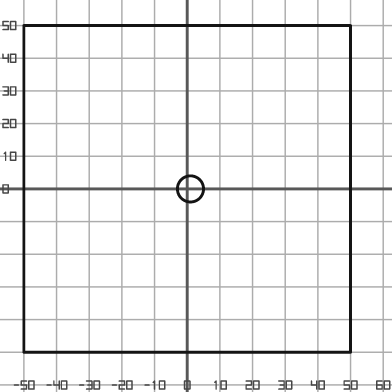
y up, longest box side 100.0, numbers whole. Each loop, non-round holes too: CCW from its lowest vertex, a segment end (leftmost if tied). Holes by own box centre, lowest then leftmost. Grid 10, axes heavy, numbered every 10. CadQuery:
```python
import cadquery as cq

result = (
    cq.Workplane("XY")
    .moveTo(-50.0, -50.0)
    .lineTo(50.0, -50.0)
    .lineTo(50.0, 50.0)
    .lineTo(-50.0, 50.0)
    .close()
    .moveTo(1.0, 0.0)
    .circle(4.0)
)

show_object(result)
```